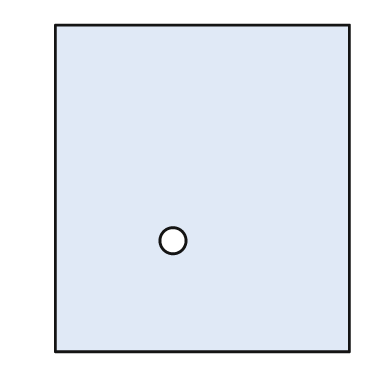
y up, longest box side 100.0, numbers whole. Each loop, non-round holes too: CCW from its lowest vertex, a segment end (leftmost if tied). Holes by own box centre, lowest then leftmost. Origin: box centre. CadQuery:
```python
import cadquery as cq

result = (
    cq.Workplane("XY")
    .moveTo(-45.0, -50.0)
    .lineTo(45.0, -50.0)
    .lineTo(45.0, 50.0)
    .lineTo(-45.0, 50.0)
    .close()
    .moveTo(-9.0, -16.0)
    .circle(4.0)
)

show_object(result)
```